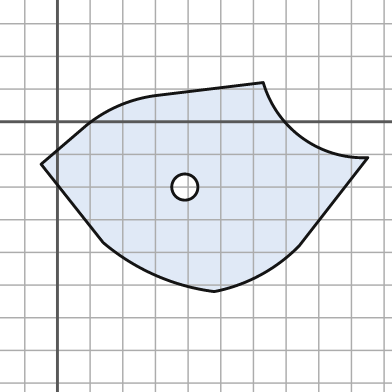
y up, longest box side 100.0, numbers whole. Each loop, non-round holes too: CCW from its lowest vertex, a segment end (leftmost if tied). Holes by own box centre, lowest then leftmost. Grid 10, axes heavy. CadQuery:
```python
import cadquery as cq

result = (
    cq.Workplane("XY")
    .moveTo(48.0, -52.0)
    .threePointArc((62.0, -47.0), (74.0, -38.0))
    .lineTo(95.0, -11.0)
    .threePointArc((75.0, -5.0), (63.0, 12.0))
    .lineTo(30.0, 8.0)
    .threePointArc((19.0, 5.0), (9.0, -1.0))
    .lineTo(-5.0, -13.0)
    .lineTo(14.0, -37.0)
    .threePointArc((30.0, -47.0), (48.0, -52.0))
    .close()
    .moveTo(39.0, -20.0)
    .circle(4.0)
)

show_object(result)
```